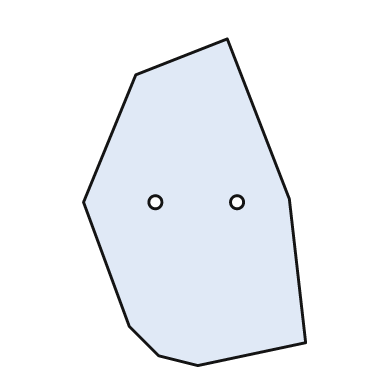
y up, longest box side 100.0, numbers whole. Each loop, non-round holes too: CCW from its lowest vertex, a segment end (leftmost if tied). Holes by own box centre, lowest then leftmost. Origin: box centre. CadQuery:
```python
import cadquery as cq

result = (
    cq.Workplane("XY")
    .moveTo(1.0, -50.0)
    .lineTo(34.0, -43.0)
    .lineTo(29.0, 1.0)
    .lineTo(10.0, 50.0)
    .lineTo(-18.0, 39.0)
    .lineTo(-34.0, 0.0)
    .lineTo(-20.0, -38.0)
    .lineTo(-11.0, -47.0)
    .close()
    .moveTo(-12.0, 0.0)
    .circle(2.0)
    .moveTo(13.0, 0.0)
    .circle(2.0)
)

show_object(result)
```